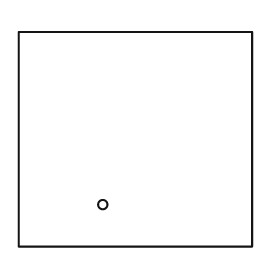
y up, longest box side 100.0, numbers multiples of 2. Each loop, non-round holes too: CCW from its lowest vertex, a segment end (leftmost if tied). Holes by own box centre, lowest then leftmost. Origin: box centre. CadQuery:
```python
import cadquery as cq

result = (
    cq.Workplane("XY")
    .moveTo(-50.0, -46.0)
    .lineTo(50.0, -46.0)
    .lineTo(50.0, 46.0)
    .lineTo(-50.0, 46.0)
    .close()
    .moveTo(-14.0, -28.0)
    .circle(2.0)
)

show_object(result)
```